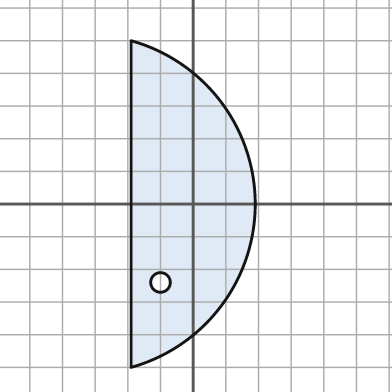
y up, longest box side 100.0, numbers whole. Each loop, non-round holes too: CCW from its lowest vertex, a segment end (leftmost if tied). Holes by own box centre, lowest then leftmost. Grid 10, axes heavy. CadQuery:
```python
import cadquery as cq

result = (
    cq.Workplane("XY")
    .moveTo(-19.0, -50.0)
    .threePointArc((19.0, 0.0), (-19.0, 50.0))
    .close()
    .moveTo(-10.0, -24.0)
    .circle(3.0)
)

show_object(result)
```